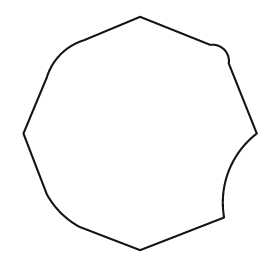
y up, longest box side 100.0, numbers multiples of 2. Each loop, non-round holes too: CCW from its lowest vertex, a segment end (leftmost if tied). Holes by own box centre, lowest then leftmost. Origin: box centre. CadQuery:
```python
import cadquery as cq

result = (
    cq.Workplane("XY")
    .moveTo(0.0, -50.0)
    .lineTo(36.0, -36.0)
    .threePointArc((38.0, -16.0), (50.0, 0.0))
    .lineTo(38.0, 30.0)
    .threePointArc((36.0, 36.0), (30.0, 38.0))
    .lineTo(0.0, 50.0)
    .lineTo(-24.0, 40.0)
    .threePointArc((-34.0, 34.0), (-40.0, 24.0))
    .lineTo(-50.0, 0.0)
    .lineTo(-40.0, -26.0)
    .threePointArc((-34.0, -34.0), (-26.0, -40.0))
    .close()
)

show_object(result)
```